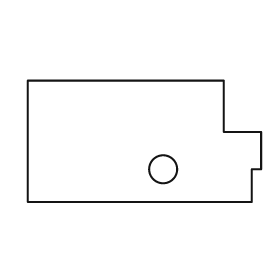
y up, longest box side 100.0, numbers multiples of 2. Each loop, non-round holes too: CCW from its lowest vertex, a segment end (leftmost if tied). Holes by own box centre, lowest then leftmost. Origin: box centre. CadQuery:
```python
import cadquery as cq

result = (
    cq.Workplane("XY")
    .moveTo(-50.0, -26.0)
    .lineTo(46.0, -26.0)
    .lineTo(46.0, -12.0)
    .lineTo(50.0, -12.0)
    .lineTo(50.0, 4.0)
    .lineTo(34.0, 4.0)
    .lineTo(34.0, 26.0)
    .lineTo(-50.0, 26.0)
    .close()
    .moveTo(8.0, -12.0)
    .circle(6.0)
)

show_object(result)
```